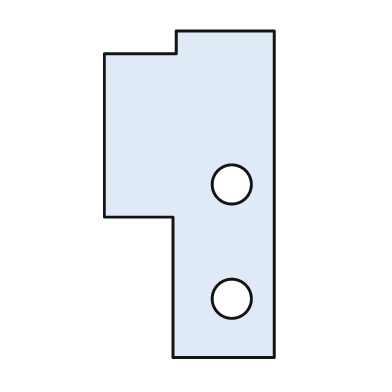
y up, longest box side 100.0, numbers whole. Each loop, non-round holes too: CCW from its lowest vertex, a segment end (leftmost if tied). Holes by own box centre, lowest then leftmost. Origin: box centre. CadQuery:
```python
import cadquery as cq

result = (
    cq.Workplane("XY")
    .moveTo(-5.0, -50.0)
    .lineTo(26.0, -50.0)
    .lineTo(26.0, 50.0)
    .lineTo(-4.0, 50.0)
    .lineTo(-4.0, 43.0)
    .lineTo(-26.0, 43.0)
    .lineTo(-26.0, -7.0)
    .lineTo(-5.0, -7.0)
    .close()
    .moveTo(13.0, -32.0)
    .circle(6.0)
    .moveTo(13.0, 3.0)
    .circle(6.0)
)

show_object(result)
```